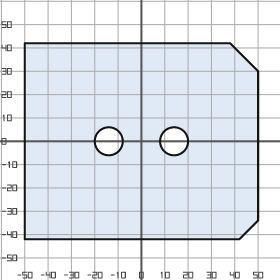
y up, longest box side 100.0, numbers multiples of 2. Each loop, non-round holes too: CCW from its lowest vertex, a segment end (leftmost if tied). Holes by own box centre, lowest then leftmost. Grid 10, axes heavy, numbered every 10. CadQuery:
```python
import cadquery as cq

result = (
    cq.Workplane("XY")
    .moveTo(-50.0, -42.0)
    .lineTo(42.0, -42.0)
    .lineTo(50.0, -34.0)
    .lineTo(50.0, 30.0)
    .lineTo(38.0, 42.0)
    .lineTo(-50.0, 42.0)
    .close()
    .moveTo(-14.0, 0.0)
    .circle(6.0)
    .moveTo(14.0, 0.0)
    .circle(6.0)
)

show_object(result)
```